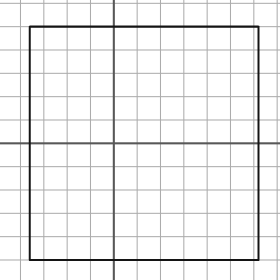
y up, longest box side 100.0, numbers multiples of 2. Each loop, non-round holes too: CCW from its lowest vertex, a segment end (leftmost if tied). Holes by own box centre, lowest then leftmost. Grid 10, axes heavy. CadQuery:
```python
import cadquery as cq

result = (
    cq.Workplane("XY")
    .moveTo(-36.0, -50.0)
    .lineTo(62.0, -50.0)
    .lineTo(62.0, 50.0)
    .lineTo(-36.0, 50.0)
    .close()
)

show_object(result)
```